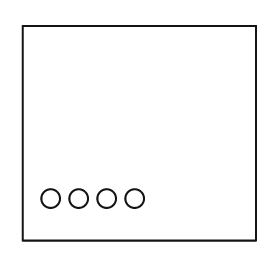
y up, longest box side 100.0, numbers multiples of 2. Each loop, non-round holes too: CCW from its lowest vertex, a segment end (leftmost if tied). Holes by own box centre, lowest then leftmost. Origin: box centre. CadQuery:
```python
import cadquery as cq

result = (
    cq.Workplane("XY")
    .moveTo(-50.0, -46.0)
    .lineTo(50.0, -46.0)
    .lineTo(50.0, 46.0)
    .lineTo(-50.0, 46.0)
    .close()
    .moveTo(-38.0, -28.0)
    .circle(4.0)
    .moveTo(-26.0, -28.0)
    .circle(4.0)
    .moveTo(-14.0, -28.0)
    .circle(4.0)
    .moveTo(-2.0, -28.0)
    .circle(4.0)
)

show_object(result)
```